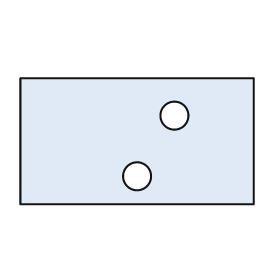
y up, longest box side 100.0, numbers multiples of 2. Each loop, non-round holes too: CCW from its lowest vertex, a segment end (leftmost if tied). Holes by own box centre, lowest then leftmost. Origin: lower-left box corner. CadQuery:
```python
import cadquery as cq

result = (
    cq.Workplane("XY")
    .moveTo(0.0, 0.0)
    .lineTo(100.0, 0.0)
    .lineTo(100.0, 54.0)
    .lineTo(0.0, 54.0)
    .close()
    .moveTo(50.0, 12.0)
    .circle(6.0)
    .moveTo(66.0, 38.0)
    .circle(6.0)
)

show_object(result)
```